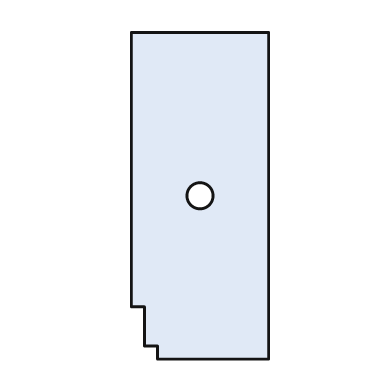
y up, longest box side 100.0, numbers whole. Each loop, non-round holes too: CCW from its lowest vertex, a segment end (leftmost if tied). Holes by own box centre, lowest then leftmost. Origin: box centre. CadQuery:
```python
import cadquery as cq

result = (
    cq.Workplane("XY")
    .moveTo(-13.0, -50.0)
    .lineTo(21.0, -50.0)
    .lineTo(21.0, 50.0)
    .lineTo(-21.0, 50.0)
    .lineTo(-21.0, -34.0)
    .lineTo(-17.0, -34.0)
    .lineTo(-17.0, -46.0)
    .lineTo(-13.0, -46.0)
    .close()
    .moveTo(0.0, 0.0)
    .circle(4.0)
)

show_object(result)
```